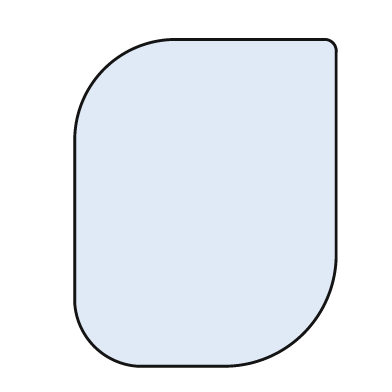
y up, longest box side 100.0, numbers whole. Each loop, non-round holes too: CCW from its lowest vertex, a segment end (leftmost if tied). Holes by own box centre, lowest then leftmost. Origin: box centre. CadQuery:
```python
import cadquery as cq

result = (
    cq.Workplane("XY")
    .moveTo(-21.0, -50.0)
    .lineTo(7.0, -50.0)
    .threePointArc((30.0, -40.0), (40.0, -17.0))
    .lineTo(40.0, 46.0)
    .threePointArc((39.0, 49.0), (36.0, 50.0))
    .lineTo(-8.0, 50.0)
    .threePointArc((-31.0, 41.0), (-40.0, 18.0))
    .lineTo(-40.0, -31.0)
    .threePointArc((-34.0, -44.0), (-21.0, -50.0))
    .close()
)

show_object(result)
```